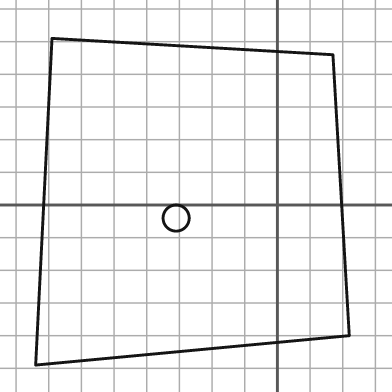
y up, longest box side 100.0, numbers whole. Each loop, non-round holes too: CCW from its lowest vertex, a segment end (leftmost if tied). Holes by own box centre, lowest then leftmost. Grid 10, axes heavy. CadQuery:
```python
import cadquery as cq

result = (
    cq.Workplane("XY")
    .moveTo(-74.0, -49.0)
    .lineTo(22.0, -40.0)
    .lineTo(17.0, 46.0)
    .lineTo(-69.0, 51.0)
    .close()
    .moveTo(-31.0, -4.0)
    .circle(4.0)
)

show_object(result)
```